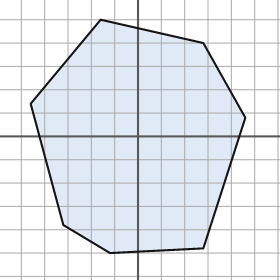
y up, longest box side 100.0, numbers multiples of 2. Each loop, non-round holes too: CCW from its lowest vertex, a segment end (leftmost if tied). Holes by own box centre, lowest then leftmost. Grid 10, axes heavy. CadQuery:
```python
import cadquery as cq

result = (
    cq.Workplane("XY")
    .moveTo(-12.0, -50.0)
    .lineTo(28.0, -48.0)
    .lineTo(46.0, 8.0)
    .lineTo(28.0, 40.0)
    .lineTo(-16.0, 50.0)
    .lineTo(-46.0, 14.0)
    .lineTo(-32.0, -38.0)
    .close()
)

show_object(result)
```